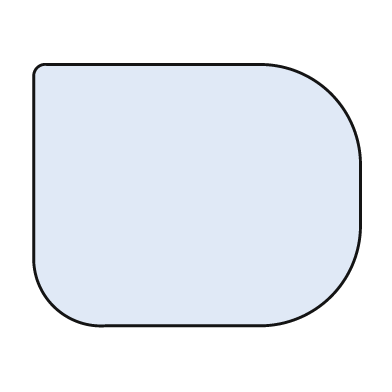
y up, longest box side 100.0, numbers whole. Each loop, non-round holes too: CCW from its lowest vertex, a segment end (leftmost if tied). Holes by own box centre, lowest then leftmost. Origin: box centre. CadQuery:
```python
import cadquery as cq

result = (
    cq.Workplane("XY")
    .moveTo(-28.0, -40.0)
    .lineTo(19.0, -40.0)
    .threePointArc((41.0, -31.0), (50.0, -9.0))
    .lineTo(50.0, 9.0)
    .threePointArc((41.0, 31.0), (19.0, 40.0))
    .lineTo(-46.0, 40.0)
    .threePointArc((-49.0, 39.0), (-50.0, 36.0))
    .lineTo(-50.0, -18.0)
    .threePointArc((-44.0, -34.0), (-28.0, -40.0))
    .close()
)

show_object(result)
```